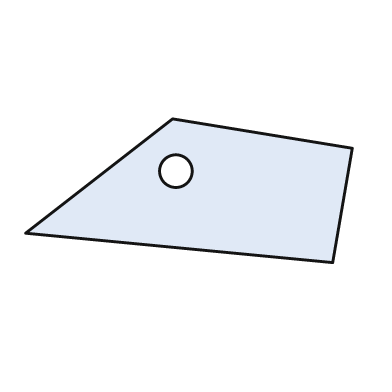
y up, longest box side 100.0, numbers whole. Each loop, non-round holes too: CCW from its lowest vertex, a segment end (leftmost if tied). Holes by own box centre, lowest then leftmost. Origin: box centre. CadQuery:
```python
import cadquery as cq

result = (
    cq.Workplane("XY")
    .moveTo(44.0, -22.0)
    .lineTo(50.0, 13.0)
    .lineTo(-5.0, 22.0)
    .lineTo(-50.0, -13.0)
    .close()
    .moveTo(-4.0, 6.0)
    .circle(5.0)
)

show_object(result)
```